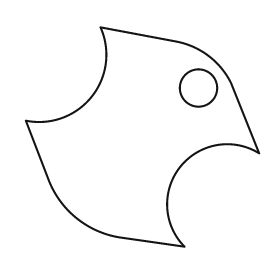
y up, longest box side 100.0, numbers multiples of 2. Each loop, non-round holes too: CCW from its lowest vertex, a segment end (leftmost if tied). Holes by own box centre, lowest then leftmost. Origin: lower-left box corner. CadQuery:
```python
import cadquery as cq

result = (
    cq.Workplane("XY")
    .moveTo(68.0, 0.0)
    .threePointArc((66.0, 34.0), (100.0, 40.0))
    .lineTo(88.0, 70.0)
    .threePointArc((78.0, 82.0), (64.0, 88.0))
    .lineTo(32.0, 94.0)
    .threePointArc((28.0, 64.0), (0.0, 54.0))
    .lineTo(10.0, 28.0)
    .threePointArc((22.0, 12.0), (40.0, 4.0))
    .close()
    .moveTo(74.0, 68.0)
    .circle(8.0)
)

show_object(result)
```